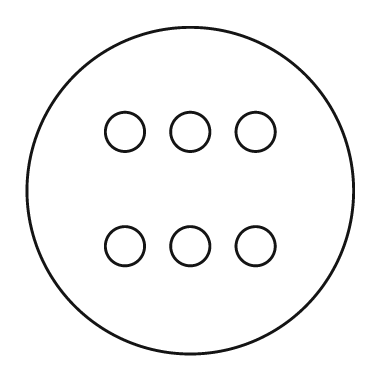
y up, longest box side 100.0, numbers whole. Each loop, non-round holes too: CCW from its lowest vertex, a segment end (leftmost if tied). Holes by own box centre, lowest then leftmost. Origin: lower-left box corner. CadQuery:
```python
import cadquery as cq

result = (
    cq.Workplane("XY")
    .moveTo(50.0, 50.0)
    .circle(50.0)
    .moveTo(30.0, 33.0)
    .circle(6.0)
    .moveTo(50.0, 33.0)
    .circle(6.0)
    .moveTo(70.0, 33.0)
    .circle(6.0)
    .moveTo(30.0, 68.0)
    .circle(6.0)
    .moveTo(50.0, 68.0)
    .circle(6.0)
    .moveTo(70.0, 68.0)
    .circle(6.0)
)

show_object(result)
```